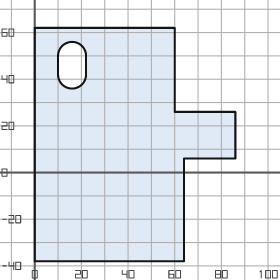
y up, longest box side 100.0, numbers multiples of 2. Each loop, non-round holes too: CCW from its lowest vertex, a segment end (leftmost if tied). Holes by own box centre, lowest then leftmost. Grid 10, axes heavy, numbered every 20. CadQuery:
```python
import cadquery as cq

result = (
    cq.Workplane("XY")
    .moveTo(0.0, -38.0)
    .lineTo(64.0, -38.0)
    .lineTo(64.0, 6.0)
    .lineTo(86.0, 6.0)
    .lineTo(86.0, 26.0)
    .lineTo(60.0, 26.0)
    .lineTo(60.0, 62.0)
    .lineTo(0.0, 62.0)
    .close()
    .moveTo(10.0, 42.0)
    .threePointArc((16.0, 36.0), (22.0, 42.0))
    .lineTo(22.0, 50.0)
    .threePointArc((16.0, 56.0), (10.0, 50.0))
    .close()
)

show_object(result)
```